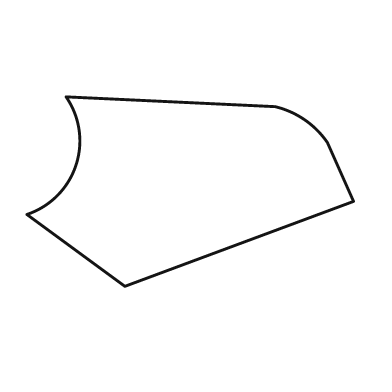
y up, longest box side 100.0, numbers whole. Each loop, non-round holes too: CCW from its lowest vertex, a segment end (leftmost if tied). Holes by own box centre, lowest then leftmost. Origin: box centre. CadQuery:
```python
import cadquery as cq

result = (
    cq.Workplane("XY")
    .moveTo(-20.0, -29.0)
    .lineTo(50.0, -3.0)
    .lineTo(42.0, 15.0)
    .threePointArc((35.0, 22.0), (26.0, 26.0))
    .lineTo(-38.0, 29.0)
    .threePointArc((-35.0, 8.0), (-50.0, -7.0))
    .close()
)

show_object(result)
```